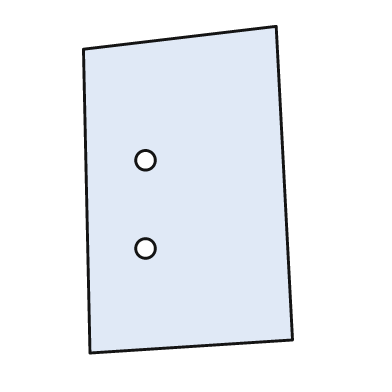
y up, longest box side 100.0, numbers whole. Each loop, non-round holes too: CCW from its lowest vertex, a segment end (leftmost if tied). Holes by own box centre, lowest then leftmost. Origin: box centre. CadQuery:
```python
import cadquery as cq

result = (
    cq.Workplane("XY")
    .moveTo(-30.0, -50.0)
    .lineTo(32.0, -46.0)
    .lineTo(27.0, 50.0)
    .lineTo(-32.0, 43.0)
    .close()
    .moveTo(-13.0, -18.0)
    .circle(3.0)
    .moveTo(-13.0, 9.0)
    .circle(3.0)
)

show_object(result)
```